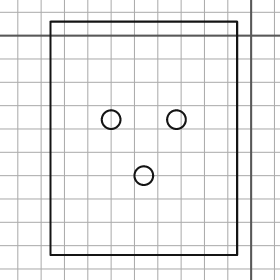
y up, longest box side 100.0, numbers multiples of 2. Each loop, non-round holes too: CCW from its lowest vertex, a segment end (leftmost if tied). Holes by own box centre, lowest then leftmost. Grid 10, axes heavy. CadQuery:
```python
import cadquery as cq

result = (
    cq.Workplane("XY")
    .moveTo(-86.0, -94.0)
    .lineTo(-6.0, -94.0)
    .lineTo(-6.0, 6.0)
    .lineTo(-86.0, 6.0)
    .close()
    .moveTo(-46.0, -60.0)
    .circle(4.0)
    .moveTo(-60.0, -36.0)
    .circle(4.0)
    .moveTo(-32.0, -36.0)
    .circle(4.0)
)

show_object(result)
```